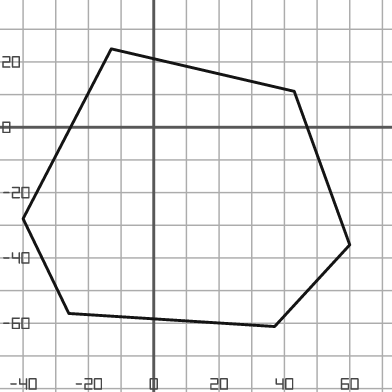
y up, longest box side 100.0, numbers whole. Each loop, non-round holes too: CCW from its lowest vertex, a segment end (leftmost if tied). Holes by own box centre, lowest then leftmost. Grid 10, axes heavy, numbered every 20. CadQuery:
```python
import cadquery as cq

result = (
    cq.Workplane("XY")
    .moveTo(37.0, -61.0)
    .lineTo(60.0, -36.0)
    .lineTo(43.0, 11.0)
    .lineTo(-13.0, 24.0)
    .lineTo(-40.0, -28.0)
    .lineTo(-26.0, -57.0)
    .close()
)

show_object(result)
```